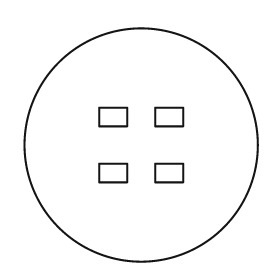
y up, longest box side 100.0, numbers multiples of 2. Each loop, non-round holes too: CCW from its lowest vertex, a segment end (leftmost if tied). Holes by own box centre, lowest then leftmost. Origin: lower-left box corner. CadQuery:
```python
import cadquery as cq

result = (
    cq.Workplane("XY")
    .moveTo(50.0, 50.0)
    .circle(50.0)
    .moveTo(32.0, 34.0)
    .lineTo(44.0, 34.0)
    .lineTo(44.0, 42.0)
    .lineTo(32.0, 42.0)
    .close()
    .moveTo(56.0, 34.0)
    .lineTo(68.0, 34.0)
    .lineTo(68.0, 42.0)
    .lineTo(56.0, 42.0)
    .close()
    .moveTo(32.0, 58.0)
    .lineTo(44.0, 58.0)
    .lineTo(44.0, 66.0)
    .lineTo(32.0, 66.0)
    .close()
    .moveTo(56.0, 58.0)
    .lineTo(68.0, 58.0)
    .lineTo(68.0, 66.0)
    .lineTo(56.0, 66.0)
    .close()
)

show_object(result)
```